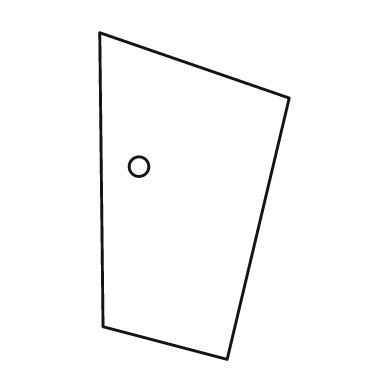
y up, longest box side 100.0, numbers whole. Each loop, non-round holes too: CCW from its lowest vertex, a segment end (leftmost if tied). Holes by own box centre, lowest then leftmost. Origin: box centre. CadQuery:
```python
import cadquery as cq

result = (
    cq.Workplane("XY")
    .moveTo(10.0, -50.0)
    .lineTo(29.0, 30.0)
    .lineTo(-29.0, 50.0)
    .lineTo(-28.0, -40.0)
    .close()
    .moveTo(-17.0, 9.0)
    .circle(3.0)
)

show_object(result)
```